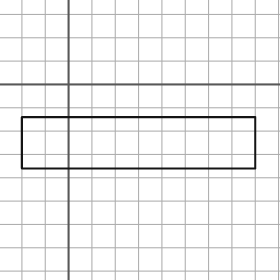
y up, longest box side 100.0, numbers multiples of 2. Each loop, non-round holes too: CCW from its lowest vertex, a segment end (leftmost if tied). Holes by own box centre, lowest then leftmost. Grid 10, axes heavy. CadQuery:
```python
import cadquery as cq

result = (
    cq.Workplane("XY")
    .moveTo(-20.0, -36.0)
    .lineTo(80.0, -36.0)
    .lineTo(80.0, -14.0)
    .lineTo(-20.0, -14.0)
    .close()
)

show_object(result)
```